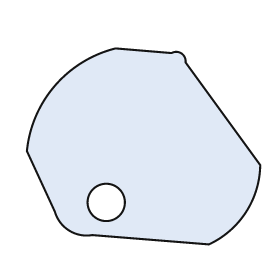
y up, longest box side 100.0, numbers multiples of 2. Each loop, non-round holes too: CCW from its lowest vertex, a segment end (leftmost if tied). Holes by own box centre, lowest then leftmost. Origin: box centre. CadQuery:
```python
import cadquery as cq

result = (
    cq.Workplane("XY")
    .moveTo(28.0, -42.0)
    .threePointArc((44.0, -28.0), (50.0, -8.0))
    .lineTo(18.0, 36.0)
    .threePointArc((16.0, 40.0), (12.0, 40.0))
    .lineTo(-12.0, 42.0)
    .threePointArc((-38.0, 26.0), (-50.0, -2.0))
    .lineTo(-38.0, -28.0)
    .threePointArc((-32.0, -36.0), (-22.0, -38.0))
    .close()
    .moveTo(-16.0, -24.0)
    .circle(8.0)
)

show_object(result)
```